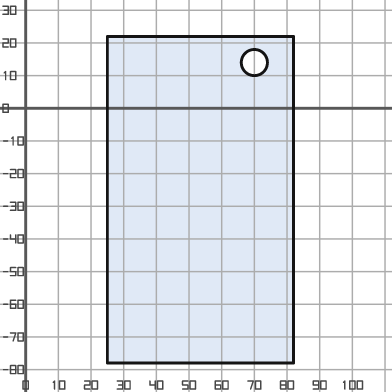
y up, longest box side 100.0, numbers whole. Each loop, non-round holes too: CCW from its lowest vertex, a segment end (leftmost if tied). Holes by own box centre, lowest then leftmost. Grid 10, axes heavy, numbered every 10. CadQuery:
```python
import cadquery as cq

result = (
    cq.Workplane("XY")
    .moveTo(25.0, -78.0)
    .lineTo(82.0, -78.0)
    .lineTo(82.0, 22.0)
    .lineTo(25.0, 22.0)
    .close()
    .moveTo(70.0, 14.0)
    .circle(4.0)
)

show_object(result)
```